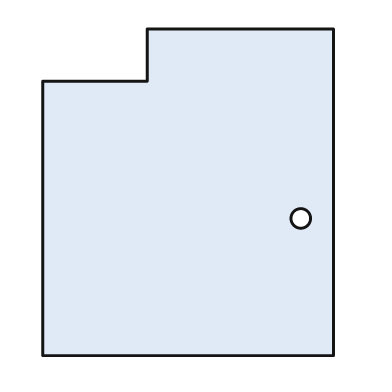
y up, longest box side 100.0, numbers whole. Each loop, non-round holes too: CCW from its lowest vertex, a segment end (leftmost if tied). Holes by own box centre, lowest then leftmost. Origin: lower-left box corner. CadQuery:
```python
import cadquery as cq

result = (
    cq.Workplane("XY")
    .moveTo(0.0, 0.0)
    .lineTo(89.0, 0.0)
    .lineTo(89.0, 100.0)
    .lineTo(32.0, 100.0)
    .lineTo(32.0, 84.0)
    .lineTo(0.0, 84.0)
    .close()
    .moveTo(79.0, 42.0)
    .circle(3.0)
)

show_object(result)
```